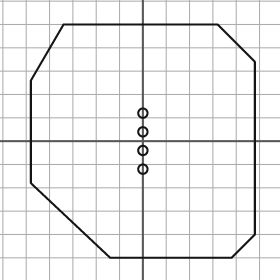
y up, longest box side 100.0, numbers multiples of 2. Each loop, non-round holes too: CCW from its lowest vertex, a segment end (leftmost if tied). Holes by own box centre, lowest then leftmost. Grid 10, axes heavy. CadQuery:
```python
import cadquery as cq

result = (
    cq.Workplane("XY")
    .moveTo(-14.0, -50.0)
    .lineTo(38.0, -50.0)
    .lineTo(48.0, -40.0)
    .lineTo(48.0, 34.0)
    .lineTo(32.0, 50.0)
    .lineTo(-34.0, 50.0)
    .lineTo(-48.0, 26.0)
    .lineTo(-48.0, -18.0)
    .close()
    .moveTo(0.0, -12.0)
    .circle(2.0)
    .moveTo(0.0, -4.0)
    .circle(2.0)
    .moveTo(0.0, 4.0)
    .circle(2.0)
    .moveTo(0.0, 12.0)
    .circle(2.0)
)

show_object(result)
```